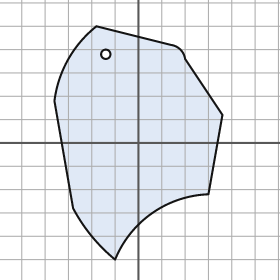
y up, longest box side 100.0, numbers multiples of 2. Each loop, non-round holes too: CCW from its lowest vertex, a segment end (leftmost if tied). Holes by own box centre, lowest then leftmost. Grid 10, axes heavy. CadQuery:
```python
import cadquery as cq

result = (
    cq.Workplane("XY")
    .moveTo(-10.0, -50.0)
    .threePointArc((6.0, -30.0), (30.0, -22.0))
    .lineTo(36.0, 12.0)
    .lineTo(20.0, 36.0)
    .threePointArc((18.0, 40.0), (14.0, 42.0))
    .lineTo(-18.0, 50.0)
    .threePointArc((-30.0, 36.0), (-36.0, 18.0))
    .lineTo(-28.0, -28.0)
    .threePointArc((-20.0, -40.0), (-10.0, -50.0))
    .close()
    .moveTo(-14.0, 38.0)
    .circle(2.0)
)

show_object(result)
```